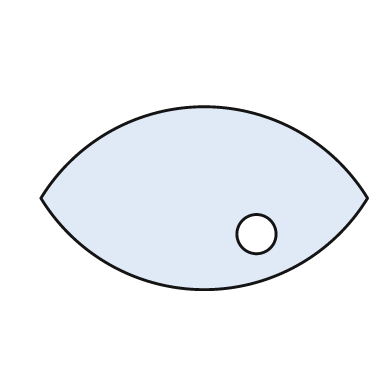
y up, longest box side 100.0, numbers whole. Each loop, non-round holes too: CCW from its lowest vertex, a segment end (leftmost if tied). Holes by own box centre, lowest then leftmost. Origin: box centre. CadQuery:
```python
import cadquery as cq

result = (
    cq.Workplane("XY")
    .moveTo(-50.0, 0.0)
    .threePointArc((0.0, -28.0), (50.0, 0.0))
    .threePointArc((0.0, 28.0), (-50.0, 0.0))
    .close()
    .moveTo(16.0, -11.0)
    .circle(6.0)
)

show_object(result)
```